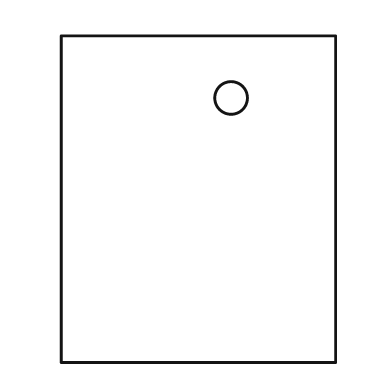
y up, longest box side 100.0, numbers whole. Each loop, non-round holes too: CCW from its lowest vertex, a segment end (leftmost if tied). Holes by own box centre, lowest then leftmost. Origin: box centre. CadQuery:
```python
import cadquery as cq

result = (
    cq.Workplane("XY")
    .moveTo(-42.0, -50.0)
    .lineTo(42.0, -50.0)
    .lineTo(42.0, 50.0)
    .lineTo(-42.0, 50.0)
    .close()
    .moveTo(10.0, 31.0)
    .circle(5.0)
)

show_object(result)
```